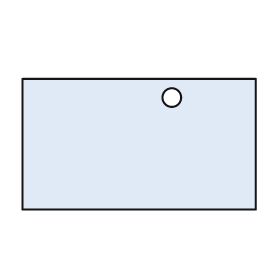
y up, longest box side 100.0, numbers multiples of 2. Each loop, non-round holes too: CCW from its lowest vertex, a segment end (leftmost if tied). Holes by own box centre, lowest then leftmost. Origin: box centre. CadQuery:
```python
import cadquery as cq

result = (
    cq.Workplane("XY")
    .moveTo(-50.0, -28.0)
    .lineTo(50.0, -28.0)
    .lineTo(50.0, 28.0)
    .lineTo(-50.0, 28.0)
    .close()
    .moveTo(14.0, 20.0)
    .circle(4.0)
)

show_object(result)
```